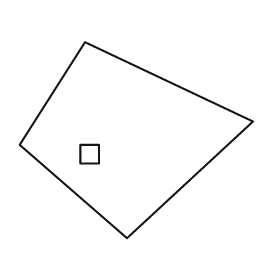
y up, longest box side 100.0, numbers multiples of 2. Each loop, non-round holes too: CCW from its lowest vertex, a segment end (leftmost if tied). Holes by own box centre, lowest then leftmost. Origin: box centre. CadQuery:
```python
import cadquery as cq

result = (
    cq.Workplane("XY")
    .moveTo(-4.0, -42.0)
    .lineTo(50.0, 8.0)
    .lineTo(-22.0, 42.0)
    .lineTo(-50.0, -2.0)
    .close()
    .moveTo(-24.0, -10.0)
    .lineTo(-16.0, -10.0)
    .lineTo(-16.0, -2.0)
    .lineTo(-24.0, -2.0)
    .close()
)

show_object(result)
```